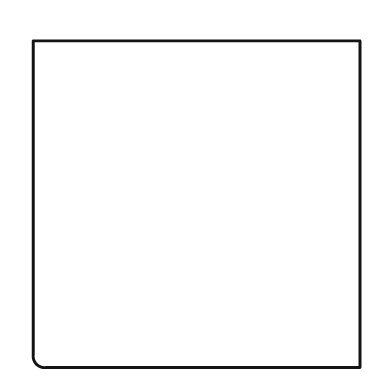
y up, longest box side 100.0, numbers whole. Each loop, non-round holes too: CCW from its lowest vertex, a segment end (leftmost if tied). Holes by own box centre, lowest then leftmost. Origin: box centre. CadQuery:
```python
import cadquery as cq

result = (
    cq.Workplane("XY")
    .moveTo(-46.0, -50.0)
    .lineTo(50.0, -50.0)
    .lineTo(50.0, 50.0)
    .lineTo(-50.0, 50.0)
    .lineTo(-50.0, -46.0)
    .threePointArc((-49.0, -49.0), (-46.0, -50.0))
    .close()
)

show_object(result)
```